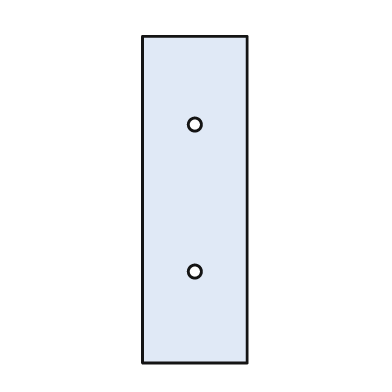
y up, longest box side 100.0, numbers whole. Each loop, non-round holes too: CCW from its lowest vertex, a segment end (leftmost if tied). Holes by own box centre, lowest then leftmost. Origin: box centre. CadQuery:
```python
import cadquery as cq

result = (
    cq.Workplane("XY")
    .moveTo(-16.0, -50.0)
    .lineTo(16.0, -50.0)
    .lineTo(16.0, 50.0)
    .lineTo(-16.0, 50.0)
    .close()
    .moveTo(0.0, -22.0)
    .circle(2.0)
    .moveTo(0.0, 23.0)
    .circle(2.0)
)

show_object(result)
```